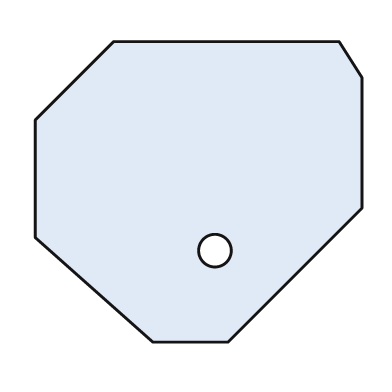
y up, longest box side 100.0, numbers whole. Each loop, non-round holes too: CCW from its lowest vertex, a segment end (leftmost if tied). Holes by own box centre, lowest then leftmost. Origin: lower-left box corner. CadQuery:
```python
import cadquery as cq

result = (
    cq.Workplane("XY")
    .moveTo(36.0, 0.0)
    .lineTo(59.0, 0.0)
    .lineTo(100.0, 41.0)
    .lineTo(100.0, 81.0)
    .lineTo(93.0, 92.0)
    .lineTo(24.0, 92.0)
    .lineTo(0.0, 68.0)
    .lineTo(0.0, 32.0)
    .close()
    .moveTo(55.0, 28.0)
    .circle(5.0)
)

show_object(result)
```